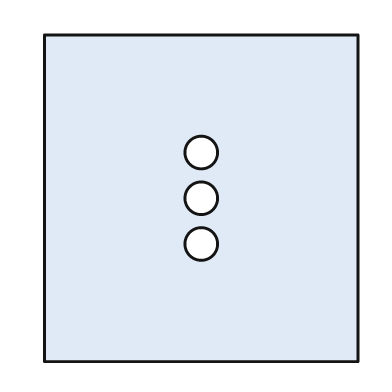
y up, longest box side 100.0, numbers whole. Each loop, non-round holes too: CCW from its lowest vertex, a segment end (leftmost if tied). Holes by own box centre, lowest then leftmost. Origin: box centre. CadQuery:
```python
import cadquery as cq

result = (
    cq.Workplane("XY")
    .moveTo(-48.0, -50.0)
    .lineTo(48.0, -50.0)
    .lineTo(48.0, 50.0)
    .lineTo(-48.0, 50.0)
    .close()
    .moveTo(0.0, -14.0)
    .circle(5.0)
    .moveTo(0.0, 0.0)
    .circle(5.0)
    .moveTo(0.0, 14.0)
    .circle(5.0)
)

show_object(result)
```